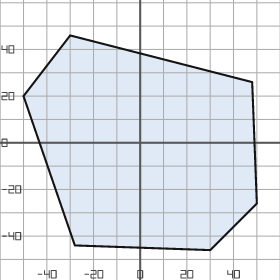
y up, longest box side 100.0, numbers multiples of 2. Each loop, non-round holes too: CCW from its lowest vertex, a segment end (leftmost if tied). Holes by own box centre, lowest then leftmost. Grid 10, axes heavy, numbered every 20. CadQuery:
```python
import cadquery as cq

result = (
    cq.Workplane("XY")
    .moveTo(30.0, -46.0)
    .lineTo(50.0, -26.0)
    .lineTo(48.0, 26.0)
    .lineTo(-30.0, 46.0)
    .lineTo(-50.0, 20.0)
    .lineTo(-28.0, -44.0)
    .close()
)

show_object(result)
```